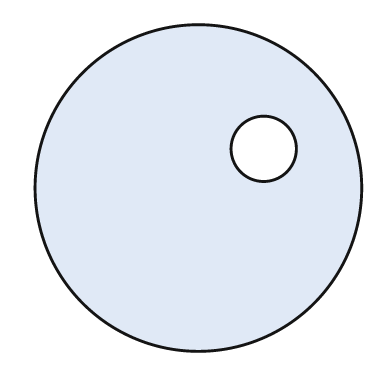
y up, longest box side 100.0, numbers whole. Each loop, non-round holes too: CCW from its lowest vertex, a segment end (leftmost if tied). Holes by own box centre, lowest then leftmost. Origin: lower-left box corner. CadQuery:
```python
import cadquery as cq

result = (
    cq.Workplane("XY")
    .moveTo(50.0, 50.0)
    .circle(50.0)
    .moveTo(70.0, 62.0)
    .circle(10.0)
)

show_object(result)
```